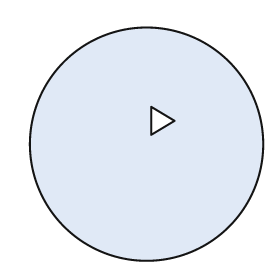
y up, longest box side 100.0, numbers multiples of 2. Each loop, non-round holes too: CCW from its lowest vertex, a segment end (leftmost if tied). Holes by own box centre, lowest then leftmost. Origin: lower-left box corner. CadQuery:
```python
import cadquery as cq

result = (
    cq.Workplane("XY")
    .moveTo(50.0, 50.0)
    .circle(50.0)
    .moveTo(52.0, 54.0)
    .lineTo(62.0, 60.0)
    .lineTo(52.0, 66.0)
    .close()
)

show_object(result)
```